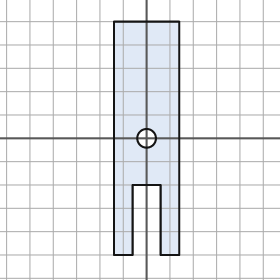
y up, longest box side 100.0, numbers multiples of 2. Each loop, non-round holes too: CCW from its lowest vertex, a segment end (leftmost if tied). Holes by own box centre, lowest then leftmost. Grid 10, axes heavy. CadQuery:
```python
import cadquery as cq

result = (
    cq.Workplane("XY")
    .moveTo(-14.0, -50.0)
    .lineTo(-6.0, -50.0)
    .lineTo(-6.0, -20.0)
    .lineTo(6.0, -20.0)
    .lineTo(6.0, -50.0)
    .lineTo(14.0, -50.0)
    .lineTo(14.0, 50.0)
    .lineTo(-14.0, 50.0)
    .close()
    .moveTo(0.0, 0.0)
    .circle(4.0)
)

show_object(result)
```